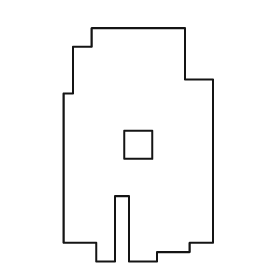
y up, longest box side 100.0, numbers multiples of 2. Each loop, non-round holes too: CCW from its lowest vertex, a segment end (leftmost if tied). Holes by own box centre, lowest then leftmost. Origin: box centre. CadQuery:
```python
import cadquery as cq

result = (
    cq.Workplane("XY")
    .moveTo(-18.0, -50.0)
    .lineTo(-10.0, -50.0)
    .lineTo(-10.0, -22.0)
    .lineTo(-4.0, -22.0)
    .lineTo(-4.0, -50.0)
    .lineTo(8.0, -50.0)
    .lineTo(8.0, -46.0)
    .lineTo(22.0, -46.0)
    .lineTo(22.0, -42.0)
    .lineTo(32.0, -42.0)
    .lineTo(32.0, 28.0)
    .lineTo(20.0, 28.0)
    .lineTo(20.0, 50.0)
    .lineTo(-20.0, 50.0)
    .lineTo(-20.0, 42.0)
    .lineTo(-28.0, 42.0)
    .lineTo(-28.0, 22.0)
    .lineTo(-32.0, 22.0)
    .lineTo(-32.0, -42.0)
    .lineTo(-18.0, -42.0)
    .close()
    .moveTo(-6.0, -6.0)
    .lineTo(6.0, -6.0)
    .lineTo(6.0, 6.0)
    .lineTo(-6.0, 6.0)
    .close()
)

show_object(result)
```